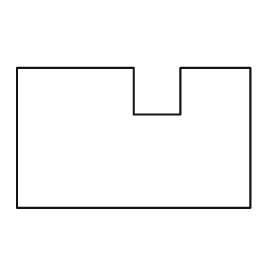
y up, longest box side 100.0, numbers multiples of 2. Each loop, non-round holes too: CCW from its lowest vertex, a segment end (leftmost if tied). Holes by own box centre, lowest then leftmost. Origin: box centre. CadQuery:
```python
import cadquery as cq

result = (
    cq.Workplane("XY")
    .moveTo(-50.0, -30.0)
    .lineTo(50.0, -30.0)
    .lineTo(50.0, 30.0)
    .lineTo(20.0, 30.0)
    .lineTo(20.0, 10.0)
    .lineTo(0.0, 10.0)
    .lineTo(0.0, 30.0)
    .lineTo(-50.0, 30.0)
    .close()
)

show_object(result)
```